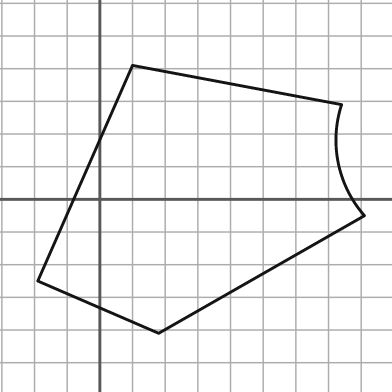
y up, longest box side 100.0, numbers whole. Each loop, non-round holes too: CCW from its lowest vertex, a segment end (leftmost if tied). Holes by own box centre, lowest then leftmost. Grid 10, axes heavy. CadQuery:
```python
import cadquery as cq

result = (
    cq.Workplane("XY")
    .moveTo(18.0, -41.0)
    .lineTo(81.0, -5.0)
    .threePointArc((73.0, 11.0), (74.0, 29.0))
    .lineTo(10.0, 41.0)
    .lineTo(-19.0, -25.0)
    .close()
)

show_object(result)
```